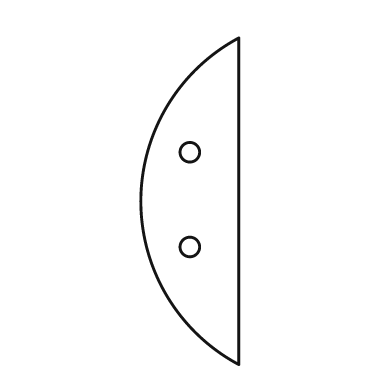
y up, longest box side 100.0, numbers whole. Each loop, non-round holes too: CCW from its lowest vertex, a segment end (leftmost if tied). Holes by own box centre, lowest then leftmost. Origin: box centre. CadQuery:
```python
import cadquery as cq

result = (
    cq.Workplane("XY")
    .moveTo(15.0, -50.0)
    .lineTo(15.0, 50.0)
    .threePointArc((-15.0, 0.0), (15.0, -50.0))
    .close()
    .moveTo(0.0, -14.0)
    .circle(3.0)
    .moveTo(0.0, 15.0)
    .circle(3.0)
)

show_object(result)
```